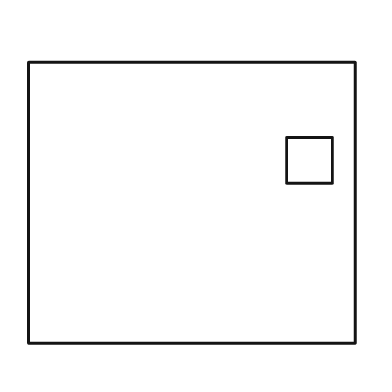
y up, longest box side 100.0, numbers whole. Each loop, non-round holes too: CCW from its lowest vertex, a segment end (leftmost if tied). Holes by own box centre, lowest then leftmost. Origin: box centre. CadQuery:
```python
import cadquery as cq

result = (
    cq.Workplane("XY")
    .moveTo(-50.0, -43.0)
    .lineTo(50.0, -43.0)
    .lineTo(50.0, 43.0)
    .lineTo(-50.0, 43.0)
    .close()
    .moveTo(29.0, 6.0)
    .lineTo(43.0, 6.0)
    .lineTo(43.0, 20.0)
    .lineTo(29.0, 20.0)
    .close()
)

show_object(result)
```